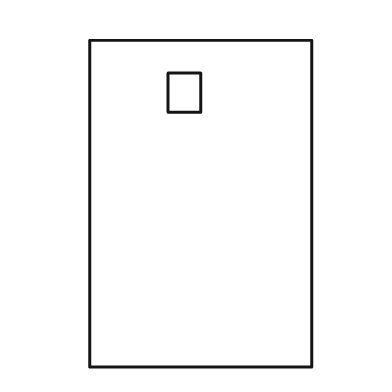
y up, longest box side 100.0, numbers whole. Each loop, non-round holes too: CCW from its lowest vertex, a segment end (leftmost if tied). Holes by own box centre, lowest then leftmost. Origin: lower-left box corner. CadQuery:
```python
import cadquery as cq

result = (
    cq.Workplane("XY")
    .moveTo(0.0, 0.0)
    .lineTo(68.0, 0.0)
    .lineTo(68.0, 100.0)
    .lineTo(0.0, 100.0)
    .close()
    .moveTo(24.0, 78.0)
    .lineTo(34.0, 78.0)
    .lineTo(34.0, 90.0)
    .lineTo(24.0, 90.0)
    .close()
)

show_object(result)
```